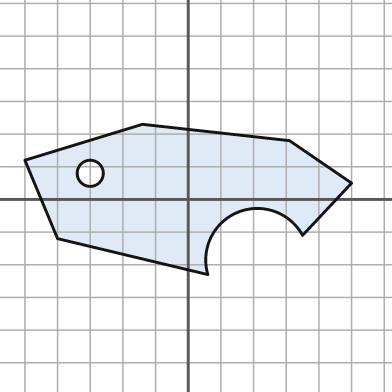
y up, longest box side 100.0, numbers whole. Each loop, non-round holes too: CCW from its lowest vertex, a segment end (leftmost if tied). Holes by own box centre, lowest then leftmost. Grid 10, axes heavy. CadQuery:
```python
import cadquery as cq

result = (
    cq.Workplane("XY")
    .moveTo(6.0, -23.0)
    .threePointArc((15.0, -4.0), (35.0, -11.0))
    .lineTo(50.0, 5.0)
    .lineTo(31.0, 18.0)
    .lineTo(-14.0, 23.0)
    .lineTo(-50.0, 12.0)
    .lineTo(-40.0, -12.0)
    .close()
    .moveTo(-30.0, 8.0)
    .circle(4.0)
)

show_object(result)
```